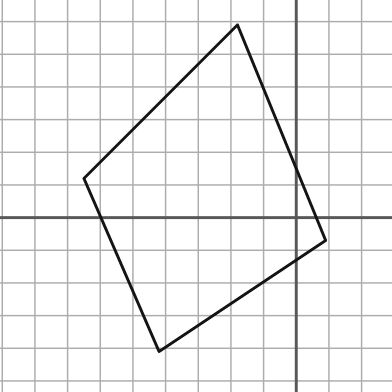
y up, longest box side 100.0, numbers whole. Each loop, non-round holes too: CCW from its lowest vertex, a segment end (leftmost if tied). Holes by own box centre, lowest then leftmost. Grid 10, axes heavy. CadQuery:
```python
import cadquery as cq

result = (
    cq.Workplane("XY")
    .moveTo(-42.0, -41.0)
    .lineTo(9.0, -7.0)
    .lineTo(-18.0, 59.0)
    .lineTo(-65.0, 12.0)
    .close()
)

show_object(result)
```